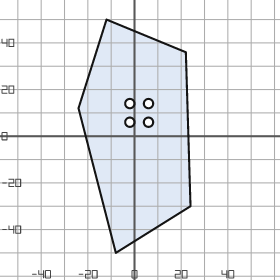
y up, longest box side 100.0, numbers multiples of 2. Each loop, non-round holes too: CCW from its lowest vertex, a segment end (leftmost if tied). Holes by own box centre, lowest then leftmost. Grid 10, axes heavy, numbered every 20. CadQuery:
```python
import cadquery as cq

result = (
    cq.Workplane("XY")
    .moveTo(-8.0, -50.0)
    .lineTo(24.0, -30.0)
    .lineTo(22.0, 36.0)
    .lineTo(-12.0, 50.0)
    .lineTo(-24.0, 12.0)
    .close()
    .moveTo(-2.0, 6.0)
    .circle(2.0)
    .moveTo(6.0, 6.0)
    .circle(2.0)
    .moveTo(-2.0, 14.0)
    .circle(2.0)
    .moveTo(6.0, 14.0)
    .circle(2.0)
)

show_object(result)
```